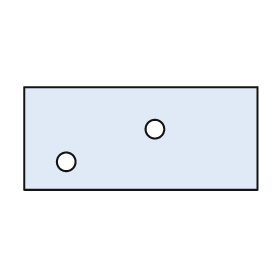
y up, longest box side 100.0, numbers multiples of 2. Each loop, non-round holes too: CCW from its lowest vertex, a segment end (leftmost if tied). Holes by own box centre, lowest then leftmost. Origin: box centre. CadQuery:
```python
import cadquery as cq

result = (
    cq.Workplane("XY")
    .moveTo(-50.0, -22.0)
    .lineTo(50.0, -22.0)
    .lineTo(50.0, 22.0)
    .lineTo(-50.0, 22.0)
    .close()
    .moveTo(-32.0, -10.0)
    .circle(4.0)
    .moveTo(6.0, 4.0)
    .circle(4.0)
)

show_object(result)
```